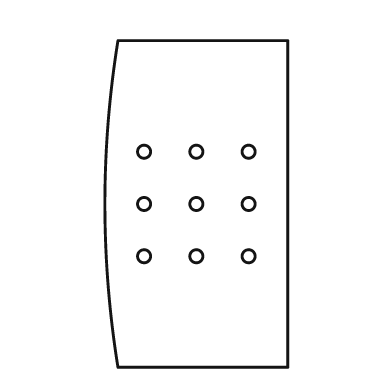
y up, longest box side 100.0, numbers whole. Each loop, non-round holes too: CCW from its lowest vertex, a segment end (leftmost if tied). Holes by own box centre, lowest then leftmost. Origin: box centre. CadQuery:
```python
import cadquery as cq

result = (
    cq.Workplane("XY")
    .moveTo(-24.0, -50.0)
    .lineTo(28.0, -50.0)
    .lineTo(28.0, 50.0)
    .lineTo(-24.0, 50.0)
    .threePointArc((-28.0, 0.0), (-24.0, -50.0))
    .close()
    .moveTo(-16.0, -16.0)
    .circle(2.0)
    .moveTo(0.0, -16.0)
    .circle(2.0)
    .moveTo(16.0, -16.0)
    .circle(2.0)
    .moveTo(-16.0, 0.0)
    .circle(2.0)
    .moveTo(0.0, 0.0)
    .circle(2.0)
    .moveTo(16.0, 0.0)
    .circle(2.0)
    .moveTo(-16.0, 16.0)
    .circle(2.0)
    .moveTo(0.0, 16.0)
    .circle(2.0)
    .moveTo(16.0, 16.0)
    .circle(2.0)
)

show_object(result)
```